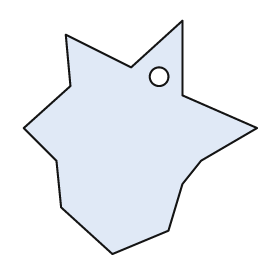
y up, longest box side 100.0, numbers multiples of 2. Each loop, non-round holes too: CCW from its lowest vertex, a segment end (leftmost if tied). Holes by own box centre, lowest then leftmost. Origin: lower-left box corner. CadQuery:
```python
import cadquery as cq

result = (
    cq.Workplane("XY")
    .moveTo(38.0, 0.0)
    .lineTo(62.0, 10.0)
    .lineTo(68.0, 30.0)
    .lineTo(76.0, 40.0)
    .lineTo(100.0, 54.0)
    .lineTo(68.0, 68.0)
    .lineTo(68.0, 100.0)
    .lineTo(46.0, 80.0)
    .lineTo(18.0, 94.0)
    .lineTo(20.0, 72.0)
    .lineTo(0.0, 54.0)
    .lineTo(14.0, 40.0)
    .lineTo(16.0, 20.0)
    .close()
    .moveTo(58.0, 76.0)
    .circle(4.0)
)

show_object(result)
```